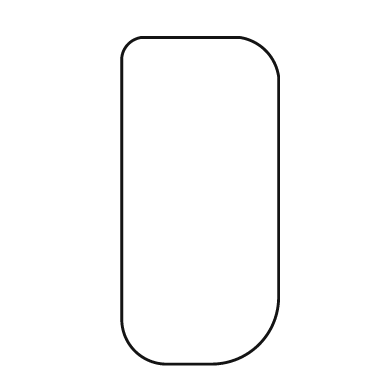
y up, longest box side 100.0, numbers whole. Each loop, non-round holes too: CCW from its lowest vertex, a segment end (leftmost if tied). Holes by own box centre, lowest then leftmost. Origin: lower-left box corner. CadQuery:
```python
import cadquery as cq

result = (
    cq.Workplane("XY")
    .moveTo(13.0, 0.0)
    .lineTo(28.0, 0.0)
    .threePointArc((42.0, 6.0), (48.0, 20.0))
    .lineTo(48.0, 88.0)
    .threePointArc((44.0, 96.0), (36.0, 100.0))
    .lineTo(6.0, 100.0)
    .threePointArc((2.0, 98.0), (0.0, 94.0))
    .lineTo(0.0, 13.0)
    .threePointArc((4.0, 4.0), (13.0, 0.0))
    .close()
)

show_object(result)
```